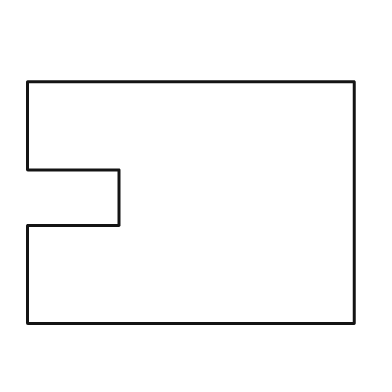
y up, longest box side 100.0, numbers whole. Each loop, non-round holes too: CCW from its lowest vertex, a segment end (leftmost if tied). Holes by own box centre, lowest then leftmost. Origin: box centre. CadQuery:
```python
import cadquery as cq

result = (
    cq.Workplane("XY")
    .moveTo(-50.0, -37.0)
    .lineTo(50.0, -37.0)
    .lineTo(50.0, 37.0)
    .lineTo(-50.0, 37.0)
    .lineTo(-50.0, 10.0)
    .lineTo(-22.0, 10.0)
    .lineTo(-22.0, -7.0)
    .lineTo(-50.0, -7.0)
    .close()
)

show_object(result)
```